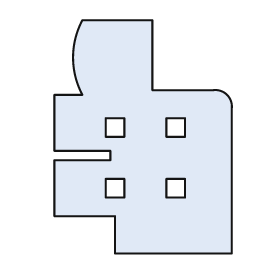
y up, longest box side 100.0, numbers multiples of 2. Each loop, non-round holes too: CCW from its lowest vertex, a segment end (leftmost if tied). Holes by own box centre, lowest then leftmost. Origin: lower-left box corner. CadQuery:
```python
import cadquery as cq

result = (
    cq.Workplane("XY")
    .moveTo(26.0, 0.0)
    .lineTo(76.0, 0.0)
    .lineTo(76.0, 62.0)
    .threePointArc((74.0, 68.0), (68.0, 70.0))
    .lineTo(42.0, 70.0)
    .lineTo(42.0, 100.0)
    .lineTo(12.0, 100.0)
    .threePointArc((8.0, 84.0), (12.0, 68.0))
    .lineTo(0.0, 68.0)
    .lineTo(0.0, 44.0)
    .lineTo(24.0, 44.0)
    .lineTo(24.0, 40.0)
    .lineTo(0.0, 40.0)
    .lineTo(0.0, 16.0)
    .lineTo(26.0, 16.0)
    .close()
    .moveTo(22.0, 24.0)
    .lineTo(30.0, 24.0)
    .lineTo(30.0, 32.0)
    .lineTo(22.0, 32.0)
    .close()
    .moveTo(48.0, 24.0)
    .lineTo(56.0, 24.0)
    .lineTo(56.0, 32.0)
    .lineTo(48.0, 32.0)
    .close()
    .moveTo(22.0, 50.0)
    .lineTo(30.0, 50.0)
    .lineTo(30.0, 58.0)
    .lineTo(22.0, 58.0)
    .close()
    .moveTo(48.0, 50.0)
    .lineTo(56.0, 50.0)
    .lineTo(56.0, 58.0)
    .lineTo(48.0, 58.0)
    .close()
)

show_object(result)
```